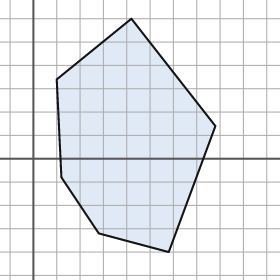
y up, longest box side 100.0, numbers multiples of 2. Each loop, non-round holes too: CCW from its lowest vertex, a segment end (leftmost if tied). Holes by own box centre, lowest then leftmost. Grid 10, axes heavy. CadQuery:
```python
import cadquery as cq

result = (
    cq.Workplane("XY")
    .moveTo(58.0, -40.0)
    .lineTo(78.0, 14.0)
    .lineTo(42.0, 60.0)
    .lineTo(10.0, 34.0)
    .lineTo(12.0, -8.0)
    .lineTo(28.0, -32.0)
    .close()
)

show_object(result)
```